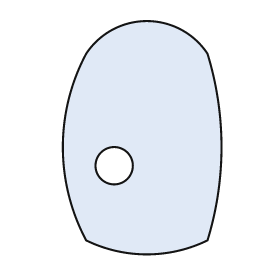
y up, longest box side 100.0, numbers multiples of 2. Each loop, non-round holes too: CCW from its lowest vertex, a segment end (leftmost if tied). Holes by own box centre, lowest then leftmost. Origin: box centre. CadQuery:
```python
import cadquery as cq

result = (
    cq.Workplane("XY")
    .moveTo(-24.0, -44.0)
    .threePointArc((2.0, -50.0), (28.0, -44.0))
    .threePointArc((34.0, -4.0), (28.0, 36.0))
    .threePointArc((2.0, 50.0), (-24.0, 36.0))
    .threePointArc((-34.0, -4.0), (-24.0, -44.0))
    .close()
    .moveTo(-12.0, -12.0)
    .circle(8.0)
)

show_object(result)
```